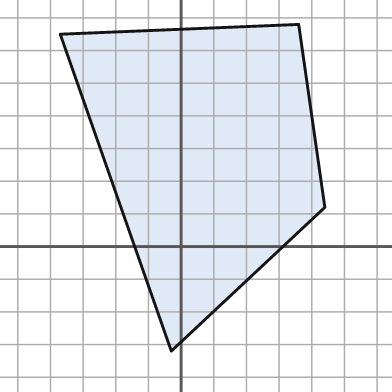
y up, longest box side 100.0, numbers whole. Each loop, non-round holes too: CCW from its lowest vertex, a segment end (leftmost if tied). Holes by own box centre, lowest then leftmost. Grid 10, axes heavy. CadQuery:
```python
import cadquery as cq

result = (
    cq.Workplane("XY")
    .moveTo(-3.0, -32.0)
    .lineTo(44.0, 12.0)
    .lineTo(36.0, 68.0)
    .lineTo(-37.0, 65.0)
    .close()
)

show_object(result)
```